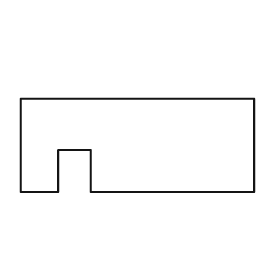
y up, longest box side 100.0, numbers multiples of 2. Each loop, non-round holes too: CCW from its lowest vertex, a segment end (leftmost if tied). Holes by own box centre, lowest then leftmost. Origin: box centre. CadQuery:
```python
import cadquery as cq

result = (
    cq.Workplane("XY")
    .moveTo(-50.0, -20.0)
    .lineTo(-34.0, -20.0)
    .lineTo(-34.0, -2.0)
    .lineTo(-20.0, -2.0)
    .lineTo(-20.0, -20.0)
    .lineTo(50.0, -20.0)
    .lineTo(50.0, 20.0)
    .lineTo(-50.0, 20.0)
    .close()
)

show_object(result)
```